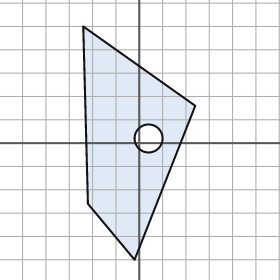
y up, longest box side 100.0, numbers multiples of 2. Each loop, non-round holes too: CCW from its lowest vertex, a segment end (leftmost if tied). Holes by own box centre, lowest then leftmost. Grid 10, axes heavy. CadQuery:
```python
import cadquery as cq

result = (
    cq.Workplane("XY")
    .moveTo(-2.0, -50.0)
    .lineTo(24.0, 16.0)
    .lineTo(-24.0, 50.0)
    .lineTo(-22.0, -26.0)
    .close()
    .moveTo(4.0, 2.0)
    .circle(6.0)
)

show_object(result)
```